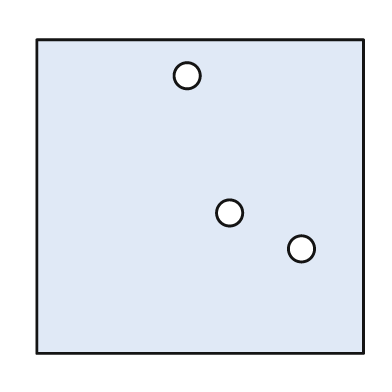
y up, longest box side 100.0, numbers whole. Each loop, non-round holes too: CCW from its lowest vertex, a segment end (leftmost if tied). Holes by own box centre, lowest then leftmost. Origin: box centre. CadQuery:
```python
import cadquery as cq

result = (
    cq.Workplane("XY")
    .moveTo(-50.0, -48.0)
    .lineTo(50.0, -48.0)
    .lineTo(50.0, 48.0)
    .lineTo(-50.0, 48.0)
    .close()
    .moveTo(31.0, -16.0)
    .circle(4.0)
    .moveTo(9.0, -5.0)
    .circle(4.0)
    .moveTo(-4.0, 37.0)
    .circle(4.0)
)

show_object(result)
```